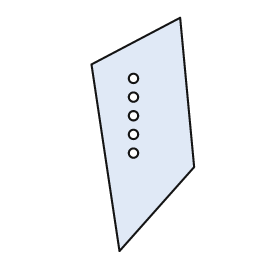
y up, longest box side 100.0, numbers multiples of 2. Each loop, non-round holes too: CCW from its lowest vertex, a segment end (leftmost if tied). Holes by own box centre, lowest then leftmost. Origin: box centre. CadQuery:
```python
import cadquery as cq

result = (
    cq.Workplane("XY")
    .moveTo(-10.0, -50.0)
    .lineTo(22.0, -14.0)
    .lineTo(16.0, 50.0)
    .lineTo(-22.0, 30.0)
    .close()
    .moveTo(-4.0, -8.0)
    .circle(2.0)
    .moveTo(-4.0, 0.0)
    .circle(2.0)
    .moveTo(-4.0, 8.0)
    .circle(2.0)
    .moveTo(-4.0, 16.0)
    .circle(2.0)
    .moveTo(-4.0, 24.0)
    .circle(2.0)
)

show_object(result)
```